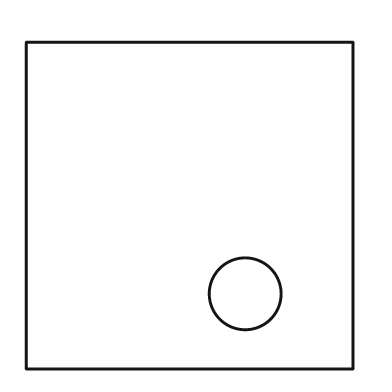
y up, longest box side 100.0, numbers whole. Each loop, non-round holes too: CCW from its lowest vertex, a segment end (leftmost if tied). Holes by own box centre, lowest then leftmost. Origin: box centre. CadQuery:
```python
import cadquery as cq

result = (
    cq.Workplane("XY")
    .moveTo(-50.0, -50.0)
    .lineTo(50.0, -50.0)
    .lineTo(50.0, 50.0)
    .lineTo(-50.0, 50.0)
    .close()
    .moveTo(17.0, -27.0)
    .circle(11.0)
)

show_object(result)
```